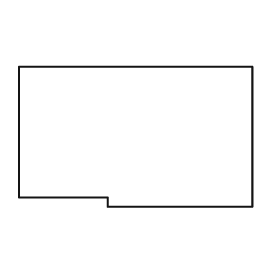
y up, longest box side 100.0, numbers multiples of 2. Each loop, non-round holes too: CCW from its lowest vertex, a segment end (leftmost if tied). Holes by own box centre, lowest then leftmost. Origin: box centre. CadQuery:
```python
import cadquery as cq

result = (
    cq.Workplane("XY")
    .moveTo(-12.0, -30.0)
    .lineTo(50.0, -30.0)
    .lineTo(50.0, 30.0)
    .lineTo(-50.0, 30.0)
    .lineTo(-50.0, -26.0)
    .lineTo(-12.0, -26.0)
    .close()
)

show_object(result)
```